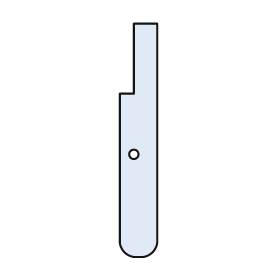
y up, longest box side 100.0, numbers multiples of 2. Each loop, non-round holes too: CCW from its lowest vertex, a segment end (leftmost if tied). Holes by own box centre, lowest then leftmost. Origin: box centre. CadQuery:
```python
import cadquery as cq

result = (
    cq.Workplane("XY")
    .moveTo(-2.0, -50.0)
    .lineTo(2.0, -50.0)
    .threePointArc((6.0, -48.0), (8.0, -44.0))
    .lineTo(8.0, 50.0)
    .lineTo(-2.0, 50.0)
    .lineTo(-2.0, 20.0)
    .lineTo(-8.0, 20.0)
    .lineTo(-8.0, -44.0)
    .threePointArc((-6.0, -48.0), (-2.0, -50.0))
    .close()
    .moveTo(-2.0, -6.0)
    .circle(2.0)
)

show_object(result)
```